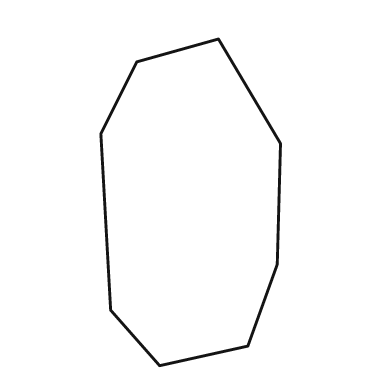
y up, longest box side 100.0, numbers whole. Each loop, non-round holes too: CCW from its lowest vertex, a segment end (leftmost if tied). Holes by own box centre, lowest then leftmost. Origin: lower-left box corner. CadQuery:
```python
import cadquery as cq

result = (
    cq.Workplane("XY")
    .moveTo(18.0, 0.0)
    .lineTo(45.0, 6.0)
    .lineTo(54.0, 31.0)
    .lineTo(55.0, 68.0)
    .lineTo(36.0, 100.0)
    .lineTo(11.0, 93.0)
    .lineTo(0.0, 71.0)
    .lineTo(3.0, 17.0)
    .close()
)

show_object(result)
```